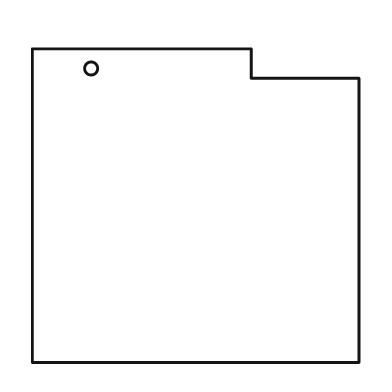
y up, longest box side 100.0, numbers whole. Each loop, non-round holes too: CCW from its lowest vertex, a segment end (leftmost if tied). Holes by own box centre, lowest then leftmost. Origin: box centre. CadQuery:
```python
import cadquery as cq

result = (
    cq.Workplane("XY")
    .moveTo(-50.0, -48.0)
    .lineTo(50.0, -48.0)
    .lineTo(50.0, 39.0)
    .lineTo(17.0, 39.0)
    .lineTo(17.0, 48.0)
    .lineTo(-50.0, 48.0)
    .close()
    .moveTo(-32.0, 42.0)
    .circle(2.0)
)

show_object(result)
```